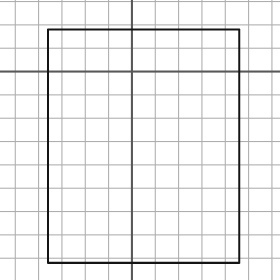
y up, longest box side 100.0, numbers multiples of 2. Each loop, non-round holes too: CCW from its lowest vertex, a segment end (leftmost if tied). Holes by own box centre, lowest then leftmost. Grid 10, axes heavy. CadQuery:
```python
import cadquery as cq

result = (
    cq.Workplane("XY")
    .moveTo(-36.0, -82.0)
    .lineTo(46.0, -82.0)
    .lineTo(46.0, 18.0)
    .lineTo(-36.0, 18.0)
    .close()
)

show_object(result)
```